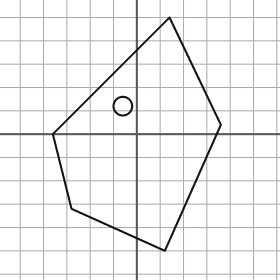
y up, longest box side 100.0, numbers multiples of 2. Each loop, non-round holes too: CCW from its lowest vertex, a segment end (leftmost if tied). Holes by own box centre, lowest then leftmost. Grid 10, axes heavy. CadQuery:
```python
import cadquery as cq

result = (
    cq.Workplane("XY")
    .moveTo(12.0, -50.0)
    .lineTo(36.0, 4.0)
    .lineTo(14.0, 50.0)
    .lineTo(-36.0, 0.0)
    .lineTo(-28.0, -32.0)
    .close()
    .moveTo(-6.0, 12.0)
    .circle(4.0)
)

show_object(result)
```